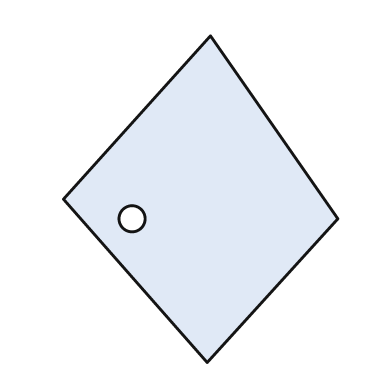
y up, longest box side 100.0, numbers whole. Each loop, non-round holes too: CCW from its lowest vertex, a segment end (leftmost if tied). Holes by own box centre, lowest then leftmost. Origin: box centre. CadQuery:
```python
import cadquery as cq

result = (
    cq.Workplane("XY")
    .moveTo(2.0, -50.0)
    .lineTo(42.0, -6.0)
    .lineTo(3.0, 50.0)
    .lineTo(-42.0, 0.0)
    .close()
    .moveTo(-21.0, -6.0)
    .circle(4.0)
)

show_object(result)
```